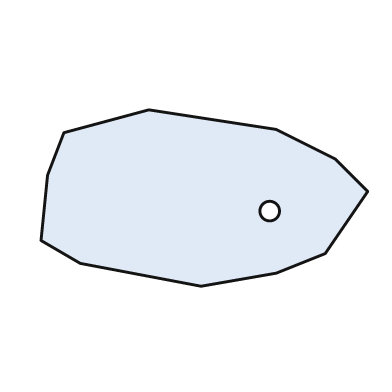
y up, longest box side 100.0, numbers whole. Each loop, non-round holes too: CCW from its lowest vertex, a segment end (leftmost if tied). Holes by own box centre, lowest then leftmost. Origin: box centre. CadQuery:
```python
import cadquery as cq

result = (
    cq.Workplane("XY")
    .moveTo(-1.0, -27.0)
    .lineTo(22.0, -23.0)
    .lineTo(37.0, -17.0)
    .lineTo(50.0, 2.0)
    .lineTo(40.0, 12.0)
    .lineTo(22.0, 21.0)
    .lineTo(-17.0, 27.0)
    .lineTo(-43.0, 20.0)
    .lineTo(-48.0, 7.0)
    .lineTo(-50.0, -13.0)
    .lineTo(-38.0, -20.0)
    .close()
    .moveTo(20.0, -4.0)
    .circle(3.0)
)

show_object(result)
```